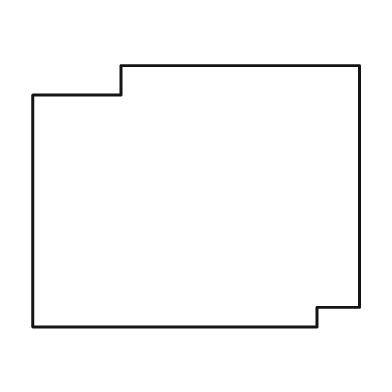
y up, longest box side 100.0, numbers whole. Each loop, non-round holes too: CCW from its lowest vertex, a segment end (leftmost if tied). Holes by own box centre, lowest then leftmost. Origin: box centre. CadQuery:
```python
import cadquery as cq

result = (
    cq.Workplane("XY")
    .moveTo(-50.0, -40.0)
    .lineTo(37.0, -40.0)
    .lineTo(37.0, -34.0)
    .lineTo(50.0, -34.0)
    .lineTo(50.0, 40.0)
    .lineTo(-23.0, 40.0)
    .lineTo(-23.0, 31.0)
    .lineTo(-50.0, 31.0)
    .close()
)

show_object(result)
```